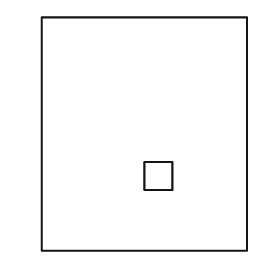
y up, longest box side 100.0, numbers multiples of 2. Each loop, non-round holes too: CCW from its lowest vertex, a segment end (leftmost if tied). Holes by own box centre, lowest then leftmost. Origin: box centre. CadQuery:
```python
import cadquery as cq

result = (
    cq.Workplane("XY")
    .moveTo(-44.0, -50.0)
    .lineTo(44.0, -50.0)
    .lineTo(44.0, 50.0)
    .lineTo(-44.0, 50.0)
    .close()
    .moveTo(0.0, -24.0)
    .lineTo(12.0, -24.0)
    .lineTo(12.0, -12.0)
    .lineTo(0.0, -12.0)
    .close()
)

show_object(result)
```